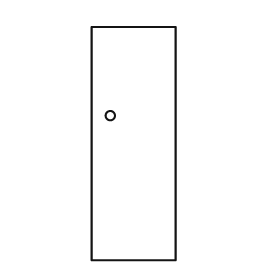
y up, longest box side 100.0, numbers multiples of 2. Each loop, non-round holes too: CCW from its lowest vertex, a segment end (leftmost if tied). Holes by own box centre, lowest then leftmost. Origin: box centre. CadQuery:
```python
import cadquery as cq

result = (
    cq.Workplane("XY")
    .moveTo(-18.0, -50.0)
    .lineTo(18.0, -50.0)
    .lineTo(18.0, 50.0)
    .lineTo(-18.0, 50.0)
    .close()
    .moveTo(-10.0, 12.0)
    .circle(2.0)
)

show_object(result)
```